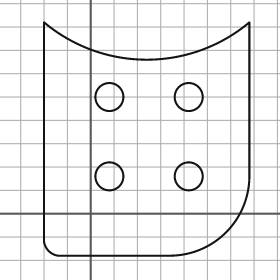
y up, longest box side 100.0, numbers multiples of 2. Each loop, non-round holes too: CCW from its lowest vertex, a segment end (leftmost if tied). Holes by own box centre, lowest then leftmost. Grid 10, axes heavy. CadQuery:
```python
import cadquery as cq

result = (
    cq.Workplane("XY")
    .moveTo(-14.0, -18.0)
    .lineTo(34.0, -18.0)
    .threePointArc((58.0, -8.0), (68.0, 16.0))
    .lineTo(68.0, 82.0)
    .threePointArc((24.0, 66.0), (-20.0, 82.0))
    .lineTo(-20.0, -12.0)
    .threePointArc((-18.0, -16.0), (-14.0, -18.0))
    .close()
    .moveTo(8.0, 16.0)
    .circle(6.0)
    .moveTo(42.0, 16.0)
    .circle(6.0)
    .moveTo(8.0, 50.0)
    .circle(6.0)
    .moveTo(42.0, 50.0)
    .circle(6.0)
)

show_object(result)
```